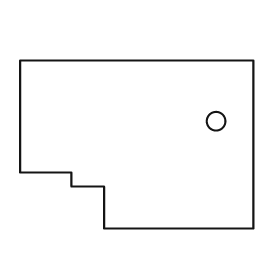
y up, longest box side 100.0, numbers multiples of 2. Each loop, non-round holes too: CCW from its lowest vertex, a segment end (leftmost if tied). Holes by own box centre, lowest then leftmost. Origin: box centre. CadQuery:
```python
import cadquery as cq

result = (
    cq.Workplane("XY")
    .moveTo(-14.0, -36.0)
    .lineTo(50.0, -36.0)
    .lineTo(50.0, 36.0)
    .lineTo(-50.0, 36.0)
    .lineTo(-50.0, -12.0)
    .lineTo(-28.0, -12.0)
    .lineTo(-28.0, -18.0)
    .lineTo(-14.0, -18.0)
    .close()
    .moveTo(34.0, 10.0)
    .circle(4.0)
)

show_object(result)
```